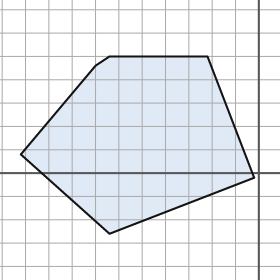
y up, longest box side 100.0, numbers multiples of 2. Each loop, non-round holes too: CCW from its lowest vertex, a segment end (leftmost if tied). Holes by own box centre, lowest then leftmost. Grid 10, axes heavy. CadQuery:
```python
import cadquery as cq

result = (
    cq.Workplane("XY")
    .moveTo(-64.0, -26.0)
    .lineTo(-2.0, -2.0)
    .lineTo(-22.0, 50.0)
    .lineTo(-64.0, 50.0)
    .lineTo(-70.0, 46.0)
    .lineTo(-102.0, 8.0)
    .close()
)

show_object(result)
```